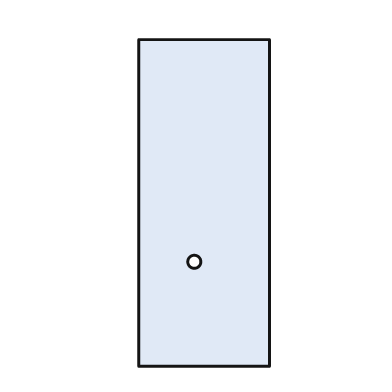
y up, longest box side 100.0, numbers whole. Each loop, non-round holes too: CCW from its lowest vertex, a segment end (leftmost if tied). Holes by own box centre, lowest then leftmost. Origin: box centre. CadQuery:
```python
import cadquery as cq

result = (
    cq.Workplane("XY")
    .moveTo(-20.0, -50.0)
    .lineTo(20.0, -50.0)
    .lineTo(20.0, 50.0)
    .lineTo(-20.0, 50.0)
    .close()
    .moveTo(-3.0, -18.0)
    .circle(2.0)
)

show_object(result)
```